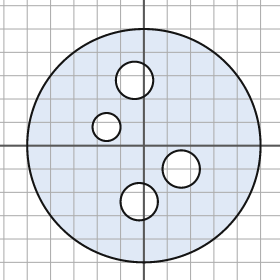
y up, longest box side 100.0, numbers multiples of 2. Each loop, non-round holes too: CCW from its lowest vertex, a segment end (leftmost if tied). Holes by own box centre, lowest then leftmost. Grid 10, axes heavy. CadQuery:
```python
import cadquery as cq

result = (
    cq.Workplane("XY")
    .moveTo(0.0, 0.0)
    .circle(50.0)
    .moveTo(-2.0, -24.0)
    .circle(8.0)
    .moveTo(16.0, -10.0)
    .circle(8.0)
    .moveTo(-16.0, 8.0)
    .circle(6.0)
    .moveTo(-4.0, 28.0)
    .circle(8.0)
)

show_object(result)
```